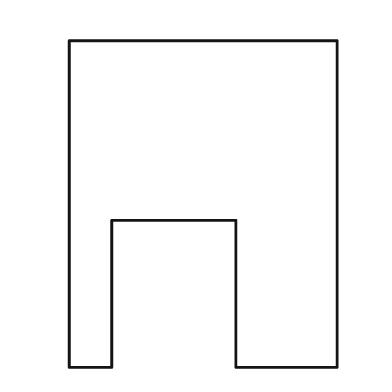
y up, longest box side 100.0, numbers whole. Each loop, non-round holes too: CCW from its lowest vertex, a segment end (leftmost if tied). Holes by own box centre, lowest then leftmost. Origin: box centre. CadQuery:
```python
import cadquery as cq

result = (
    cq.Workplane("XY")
    .moveTo(-41.0, -50.0)
    .lineTo(-28.0, -50.0)
    .lineTo(-28.0, -5.0)
    .lineTo(10.0, -5.0)
    .lineTo(10.0, -50.0)
    .lineTo(41.0, -50.0)
    .lineTo(41.0, 50.0)
    .lineTo(-41.0, 50.0)
    .close()
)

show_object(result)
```